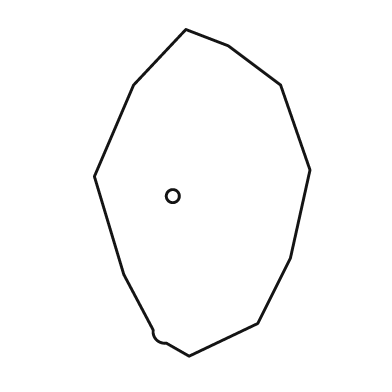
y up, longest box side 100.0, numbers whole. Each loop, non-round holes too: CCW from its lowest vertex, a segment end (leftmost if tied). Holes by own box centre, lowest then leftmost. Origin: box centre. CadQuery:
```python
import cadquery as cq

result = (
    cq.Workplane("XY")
    .moveTo(-4.0, -50.0)
    .lineTo(17.0, -40.0)
    .lineTo(27.0, -20.0)
    .lineTo(33.0, 7.0)
    .lineTo(24.0, 33.0)
    .lineTo(8.0, 45.0)
    .lineTo(-5.0, 50.0)
    .lineTo(-21.0, 33.0)
    .lineTo(-33.0, 5.0)
    .lineTo(-24.0, -25.0)
    .lineTo(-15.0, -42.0)
    .threePointArc((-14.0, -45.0), (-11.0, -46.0))
    .close()
    .moveTo(-9.0, -1.0)
    .circle(2.0)
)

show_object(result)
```